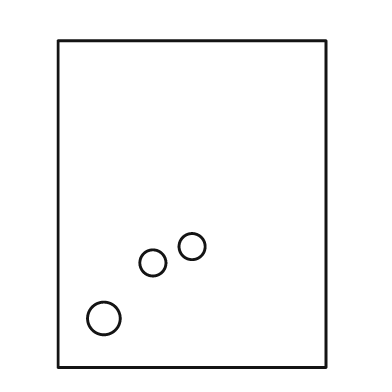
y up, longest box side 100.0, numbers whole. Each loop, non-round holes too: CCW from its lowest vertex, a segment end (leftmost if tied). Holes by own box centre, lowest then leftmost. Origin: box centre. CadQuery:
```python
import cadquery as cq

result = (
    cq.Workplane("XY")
    .moveTo(-41.0, -50.0)
    .lineTo(41.0, -50.0)
    .lineTo(41.0, 50.0)
    .lineTo(-41.0, 50.0)
    .close()
    .moveTo(-27.0, -35.0)
    .circle(5.0)
    .moveTo(-12.0, -18.0)
    .circle(4.0)
    .moveTo(0.0, -13.0)
    .circle(4.0)
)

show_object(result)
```